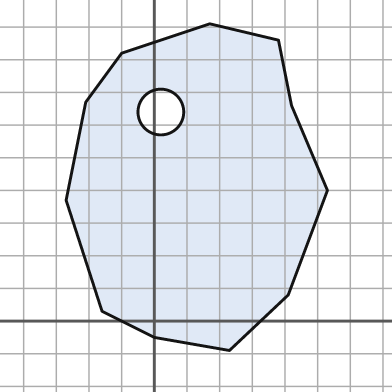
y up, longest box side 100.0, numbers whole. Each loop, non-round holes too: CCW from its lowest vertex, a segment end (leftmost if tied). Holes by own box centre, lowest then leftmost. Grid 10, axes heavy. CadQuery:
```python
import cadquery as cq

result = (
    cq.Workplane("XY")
    .moveTo(23.0, -9.0)
    .lineTo(41.0, 8.0)
    .lineTo(53.0, 40.0)
    .lineTo(42.0, 66.0)
    .lineTo(38.0, 86.0)
    .lineTo(17.0, 91.0)
    .lineTo(-10.0, 82.0)
    .lineTo(-21.0, 67.0)
    .lineTo(-27.0, 37.0)
    .lineTo(-16.0, 3.0)
    .lineTo(0.0, -5.0)
    .close()
    .moveTo(2.0, 64.0)
    .circle(7.0)
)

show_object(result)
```